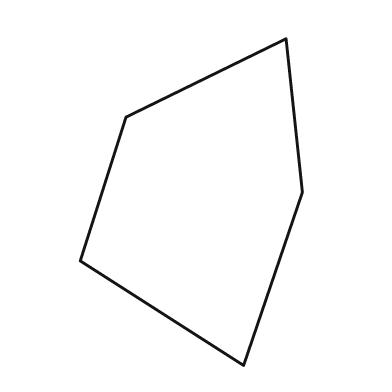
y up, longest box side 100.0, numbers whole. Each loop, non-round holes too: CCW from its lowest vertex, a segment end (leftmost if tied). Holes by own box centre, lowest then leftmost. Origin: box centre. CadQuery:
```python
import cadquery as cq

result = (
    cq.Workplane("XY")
    .moveTo(16.0, -50.0)
    .lineTo(34.0, 3.0)
    .lineTo(29.0, 50.0)
    .lineTo(-20.0, 26.0)
    .lineTo(-34.0, -18.0)
    .close()
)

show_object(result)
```